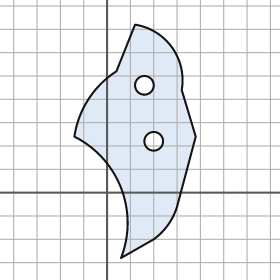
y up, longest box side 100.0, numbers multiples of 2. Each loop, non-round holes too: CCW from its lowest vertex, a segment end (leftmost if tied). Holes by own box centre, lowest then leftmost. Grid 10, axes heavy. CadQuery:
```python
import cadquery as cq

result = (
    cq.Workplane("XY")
    .moveTo(6.0, -28.0)
    .lineTo(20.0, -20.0)
    .threePointArc((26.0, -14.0), (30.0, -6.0))
    .lineTo(38.0, 24.0)
    .lineTo(32.0, 44.0)
    .threePointArc((28.0, 62.0), (12.0, 72.0))
    .lineTo(4.0, 52.0)
    .threePointArc((-8.0, 40.0), (-14.0, 24.0))
    .threePointArc((6.0, 2.0), (6.0, -28.0))
    .close()
    .moveTo(20.0, 22.0)
    .circle(4.0)
    .moveTo(16.0, 46.0)
    .circle(4.0)
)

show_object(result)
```